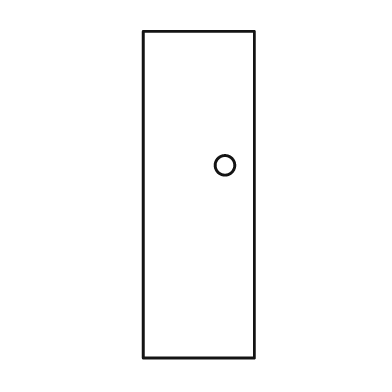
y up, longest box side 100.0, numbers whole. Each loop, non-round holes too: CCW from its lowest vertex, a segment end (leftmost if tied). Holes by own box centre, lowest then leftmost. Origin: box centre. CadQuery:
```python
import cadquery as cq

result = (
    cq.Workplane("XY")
    .moveTo(-17.0, -50.0)
    .lineTo(17.0, -50.0)
    .lineTo(17.0, 50.0)
    .lineTo(-17.0, 50.0)
    .close()
    .moveTo(8.0, 9.0)
    .circle(3.0)
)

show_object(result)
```